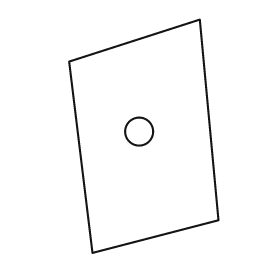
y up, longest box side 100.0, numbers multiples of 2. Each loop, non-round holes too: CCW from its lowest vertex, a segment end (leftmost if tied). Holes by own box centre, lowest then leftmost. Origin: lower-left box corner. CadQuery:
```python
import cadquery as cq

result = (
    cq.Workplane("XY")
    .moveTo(10.0, 0.0)
    .lineTo(64.0, 14.0)
    .lineTo(56.0, 100.0)
    .lineTo(0.0, 82.0)
    .close()
    .moveTo(30.0, 52.0)
    .circle(6.0)
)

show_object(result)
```